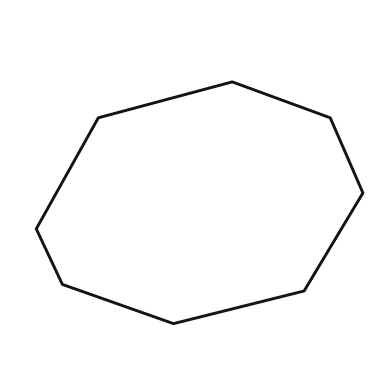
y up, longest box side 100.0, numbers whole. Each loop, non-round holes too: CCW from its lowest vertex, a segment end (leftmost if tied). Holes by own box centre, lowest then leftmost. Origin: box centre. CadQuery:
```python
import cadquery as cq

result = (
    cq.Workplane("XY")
    .moveTo(-8.0, -37.0)
    .lineTo(32.0, -27.0)
    .lineTo(50.0, 3.0)
    .lineTo(40.0, 26.0)
    .lineTo(10.0, 37.0)
    .lineTo(-31.0, 26.0)
    .lineTo(-50.0, -8.0)
    .lineTo(-42.0, -25.0)
    .close()
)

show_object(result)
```